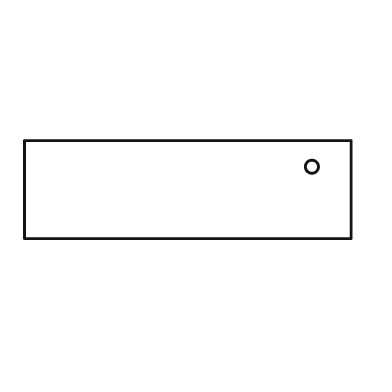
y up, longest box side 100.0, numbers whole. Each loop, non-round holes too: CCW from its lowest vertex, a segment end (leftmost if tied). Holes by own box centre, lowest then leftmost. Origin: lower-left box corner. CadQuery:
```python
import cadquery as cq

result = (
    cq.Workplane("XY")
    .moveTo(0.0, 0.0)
    .lineTo(100.0, 0.0)
    .lineTo(100.0, 30.0)
    .lineTo(0.0, 30.0)
    .close()
    .moveTo(88.0, 22.0)
    .circle(2.0)
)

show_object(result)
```